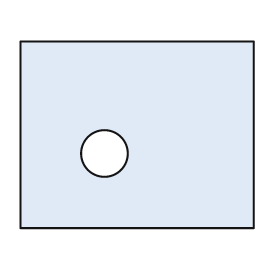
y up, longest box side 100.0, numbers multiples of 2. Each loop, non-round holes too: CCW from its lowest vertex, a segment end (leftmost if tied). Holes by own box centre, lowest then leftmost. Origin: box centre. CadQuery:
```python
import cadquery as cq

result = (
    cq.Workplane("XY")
    .moveTo(-50.0, -40.0)
    .lineTo(50.0, -40.0)
    .lineTo(50.0, 40.0)
    .lineTo(-50.0, 40.0)
    .close()
    .moveTo(-14.0, -8.0)
    .circle(10.0)
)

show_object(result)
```